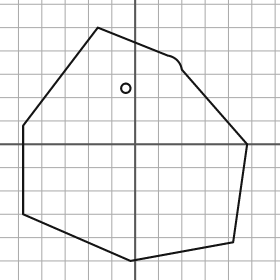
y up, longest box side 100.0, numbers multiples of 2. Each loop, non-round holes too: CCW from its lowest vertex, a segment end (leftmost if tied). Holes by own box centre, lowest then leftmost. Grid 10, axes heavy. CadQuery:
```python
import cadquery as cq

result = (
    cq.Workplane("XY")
    .moveTo(-2.0, -50.0)
    .lineTo(42.0, -42.0)
    .lineTo(48.0, 0.0)
    .lineTo(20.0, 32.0)
    .threePointArc((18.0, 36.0), (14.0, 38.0))
    .lineTo(-16.0, 50.0)
    .lineTo(-48.0, 8.0)
    .lineTo(-48.0, -30.0)
    .close()
    .moveTo(-4.0, 24.0)
    .circle(2.0)
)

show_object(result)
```